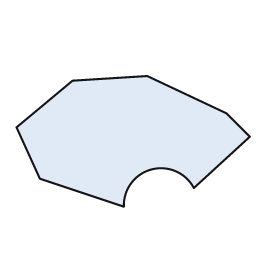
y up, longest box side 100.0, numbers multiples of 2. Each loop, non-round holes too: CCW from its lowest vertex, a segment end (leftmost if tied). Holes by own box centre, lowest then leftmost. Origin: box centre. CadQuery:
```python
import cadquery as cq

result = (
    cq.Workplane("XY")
    .moveTo(-4.0, -28.0)
    .threePointArc((8.0, -12.0), (26.0, -20.0))
    .lineTo(50.0, 2.0)
    .lineTo(40.0, 12.0)
    .lineTo(6.0, 28.0)
    .lineTo(-26.0, 26.0)
    .lineTo(-50.0, 6.0)
    .lineTo(-40.0, -16.0)
    .close()
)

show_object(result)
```